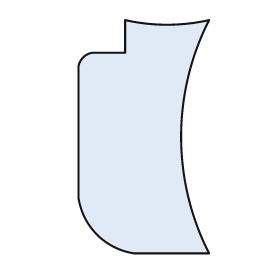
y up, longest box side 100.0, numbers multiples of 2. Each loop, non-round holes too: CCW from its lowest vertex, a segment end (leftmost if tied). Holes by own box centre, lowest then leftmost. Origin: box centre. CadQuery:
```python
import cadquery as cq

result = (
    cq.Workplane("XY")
    .moveTo(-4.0, -50.0)
    .lineTo(28.0, -50.0)
    .threePointArc((16.0, 0.0), (28.0, 50.0))
    .threePointArc((10.0, 48.0), (-8.0, 50.0))
    .lineTo(-8.0, 36.0)
    .lineTo(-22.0, 36.0)
    .threePointArc((-26.0, 34.0), (-28.0, 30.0))
    .lineTo(-28.0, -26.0)
    .threePointArc((-20.0, -42.0), (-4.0, -50.0))
    .close()
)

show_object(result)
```